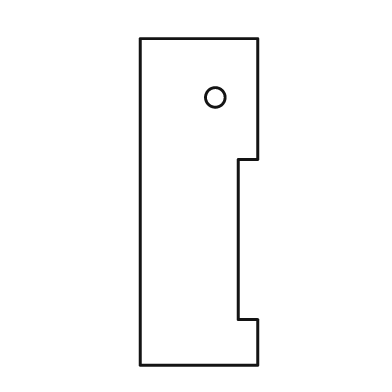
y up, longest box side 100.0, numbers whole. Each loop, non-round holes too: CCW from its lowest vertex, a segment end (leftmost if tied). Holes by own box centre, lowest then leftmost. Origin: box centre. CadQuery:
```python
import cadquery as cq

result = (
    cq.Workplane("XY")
    .moveTo(-18.0, -50.0)
    .lineTo(18.0, -50.0)
    .lineTo(18.0, -36.0)
    .lineTo(12.0, -36.0)
    .lineTo(12.0, 13.0)
    .lineTo(18.0, 13.0)
    .lineTo(18.0, 50.0)
    .lineTo(-18.0, 50.0)
    .close()
    .moveTo(5.0, 32.0)
    .circle(3.0)
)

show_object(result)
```